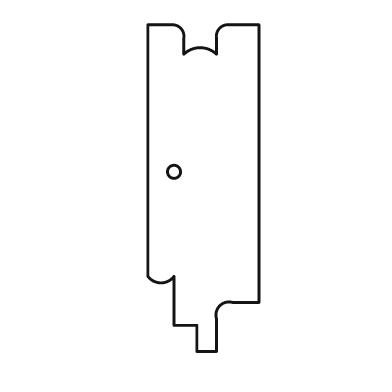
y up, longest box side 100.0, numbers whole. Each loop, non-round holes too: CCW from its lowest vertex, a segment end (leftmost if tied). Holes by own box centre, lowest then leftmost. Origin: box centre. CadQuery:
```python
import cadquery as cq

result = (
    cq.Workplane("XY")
    .moveTo(-2.0, -50.0)
    .lineTo(4.0, -50.0)
    .lineTo(4.0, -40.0)
    .threePointArc((5.0, -36.0), (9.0, -35.0))
    .lineTo(17.0, -35.0)
    .lineTo(17.0, 50.0)
    .lineTo(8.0, 50.0)
    .threePointArc((5.0, 49.0), (4.0, 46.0))
    .lineTo(4.0, 41.0)
    .threePointArc((-1.0, 43.0), (-6.0, 41.0))
    .lineTo(-6.0, 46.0)
    .threePointArc((-7.0, 49.0), (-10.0, 50.0))
    .lineTo(-17.0, 50.0)
    .lineTo(-17.0, -27.0)
    .threePointArc((-13.0, -29.0), (-9.0, -27.0))
    .lineTo(-9.0, -42.0)
    .lineTo(-2.0, -42.0)
    .close()
    .moveTo(-9.0, 5.0)
    .circle(2.0)
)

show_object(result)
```